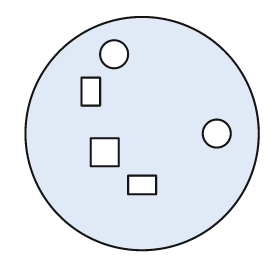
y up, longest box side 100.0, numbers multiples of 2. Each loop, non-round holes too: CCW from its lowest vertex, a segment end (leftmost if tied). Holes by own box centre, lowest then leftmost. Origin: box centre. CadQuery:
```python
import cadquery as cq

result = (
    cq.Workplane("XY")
    .moveTo(0.0, 0.0)
    .circle(50.0)
    .moveTo(-6.0, -26.0)
    .lineTo(6.0, -26.0)
    .lineTo(6.0, -18.0)
    .lineTo(-6.0, -18.0)
    .close()
    .moveTo(-22.0, -14.0)
    .lineTo(-10.0, -14.0)
    .lineTo(-10.0, -2.0)
    .lineTo(-22.0, -2.0)
    .close()
    .moveTo(32.0, 0.0)
    .circle(6.0)
    .moveTo(-26.0, 12.0)
    .lineTo(-18.0, 12.0)
    .lineTo(-18.0, 24.0)
    .lineTo(-26.0, 24.0)
    .close()
    .moveTo(-12.0, 34.0)
    .circle(6.0)
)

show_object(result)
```